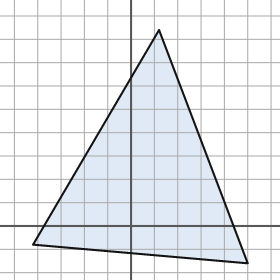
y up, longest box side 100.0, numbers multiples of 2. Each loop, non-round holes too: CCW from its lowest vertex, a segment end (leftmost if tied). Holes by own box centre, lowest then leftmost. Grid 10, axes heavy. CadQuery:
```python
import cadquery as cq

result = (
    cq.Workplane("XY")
    .moveTo(50.0, -16.0)
    .lineTo(12.0, 84.0)
    .lineTo(-42.0, -8.0)
    .close()
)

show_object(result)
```